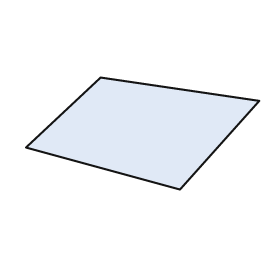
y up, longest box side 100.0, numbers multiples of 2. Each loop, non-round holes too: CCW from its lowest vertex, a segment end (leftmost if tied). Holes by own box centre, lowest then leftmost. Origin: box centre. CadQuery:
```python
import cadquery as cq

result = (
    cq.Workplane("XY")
    .moveTo(16.0, -24.0)
    .lineTo(50.0, 14.0)
    .lineTo(-18.0, 24.0)
    .lineTo(-50.0, -6.0)
    .close()
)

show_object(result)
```